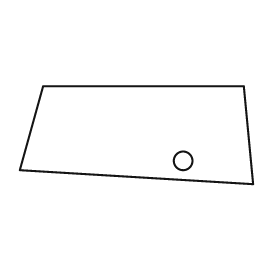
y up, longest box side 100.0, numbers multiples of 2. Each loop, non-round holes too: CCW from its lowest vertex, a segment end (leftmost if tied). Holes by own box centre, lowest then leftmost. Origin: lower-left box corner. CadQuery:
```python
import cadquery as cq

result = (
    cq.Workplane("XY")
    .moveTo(100.0, 0.0)
    .lineTo(96.0, 42.0)
    .lineTo(10.0, 42.0)
    .lineTo(0.0, 6.0)
    .close()
    .moveTo(70.0, 10.0)
    .circle(4.0)
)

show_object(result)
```